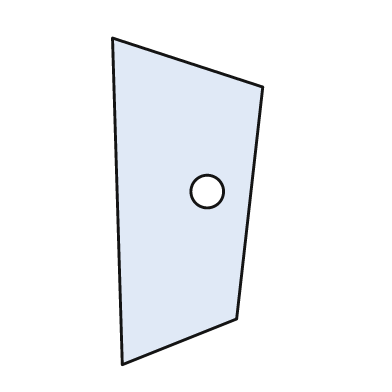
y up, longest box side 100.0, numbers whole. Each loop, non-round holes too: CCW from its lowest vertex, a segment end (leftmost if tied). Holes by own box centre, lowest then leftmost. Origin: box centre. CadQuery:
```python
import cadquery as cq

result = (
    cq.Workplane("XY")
    .moveTo(-20.0, -50.0)
    .lineTo(15.0, -36.0)
    .lineTo(23.0, 35.0)
    .lineTo(-23.0, 50.0)
    .close()
    .moveTo(6.0, 3.0)
    .circle(5.0)
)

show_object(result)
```